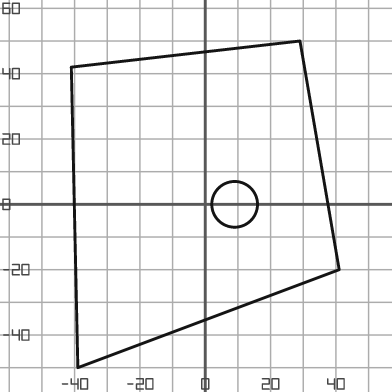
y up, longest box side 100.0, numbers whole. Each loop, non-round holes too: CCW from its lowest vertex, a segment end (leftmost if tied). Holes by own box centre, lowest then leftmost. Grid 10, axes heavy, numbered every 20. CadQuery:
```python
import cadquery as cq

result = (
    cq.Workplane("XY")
    .moveTo(-39.0, -50.0)
    .lineTo(41.0, -20.0)
    .lineTo(29.0, 50.0)
    .lineTo(-41.0, 42.0)
    .close()
    .moveTo(9.0, 0.0)
    .circle(7.0)
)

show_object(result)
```